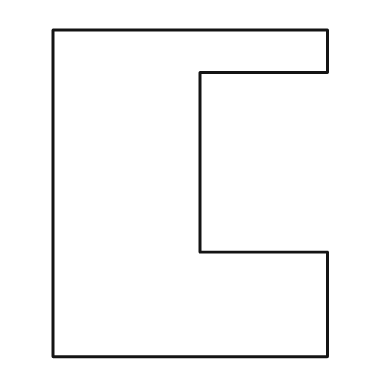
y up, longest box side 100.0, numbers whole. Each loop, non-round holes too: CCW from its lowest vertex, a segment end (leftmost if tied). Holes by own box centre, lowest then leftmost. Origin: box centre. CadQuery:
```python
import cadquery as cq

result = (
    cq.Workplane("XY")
    .moveTo(-42.0, -50.0)
    .lineTo(42.0, -50.0)
    .lineTo(42.0, -18.0)
    .lineTo(3.0, -18.0)
    .lineTo(3.0, 37.0)
    .lineTo(42.0, 37.0)
    .lineTo(42.0, 50.0)
    .lineTo(-42.0, 50.0)
    .close()
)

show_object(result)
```